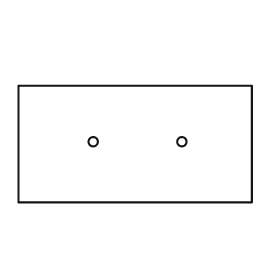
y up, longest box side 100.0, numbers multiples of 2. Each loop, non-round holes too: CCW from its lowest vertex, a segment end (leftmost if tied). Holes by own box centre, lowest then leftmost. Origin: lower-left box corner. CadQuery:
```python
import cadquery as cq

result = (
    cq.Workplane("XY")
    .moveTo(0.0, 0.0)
    .lineTo(100.0, 0.0)
    .lineTo(100.0, 50.0)
    .lineTo(0.0, 50.0)
    .close()
    .moveTo(32.0, 26.0)
    .circle(2.0)
    .moveTo(70.0, 26.0)
    .circle(2.0)
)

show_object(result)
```